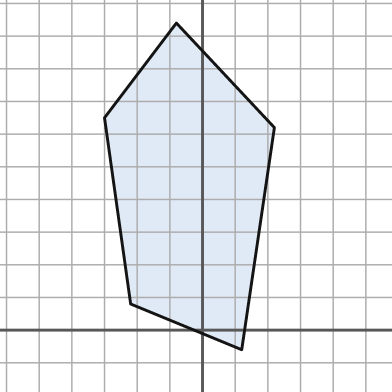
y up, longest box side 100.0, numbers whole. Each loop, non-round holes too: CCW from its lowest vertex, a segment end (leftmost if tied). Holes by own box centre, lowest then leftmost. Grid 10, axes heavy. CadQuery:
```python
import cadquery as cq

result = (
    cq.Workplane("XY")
    .moveTo(12.0, -6.0)
    .lineTo(22.0, 62.0)
    .lineTo(-8.0, 94.0)
    .lineTo(-30.0, 65.0)
    .lineTo(-22.0, 8.0)
    .close()
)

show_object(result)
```